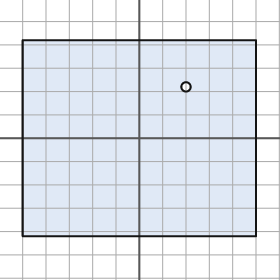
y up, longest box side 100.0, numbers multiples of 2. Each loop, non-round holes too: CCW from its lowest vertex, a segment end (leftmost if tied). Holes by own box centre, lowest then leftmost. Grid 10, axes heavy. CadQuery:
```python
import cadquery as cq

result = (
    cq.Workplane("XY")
    .moveTo(-50.0, -42.0)
    .lineTo(50.0, -42.0)
    .lineTo(50.0, 42.0)
    .lineTo(-50.0, 42.0)
    .close()
    .moveTo(20.0, 22.0)
    .circle(2.0)
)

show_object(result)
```